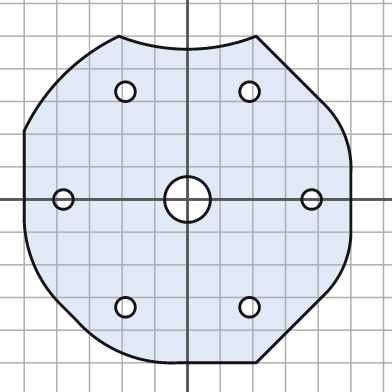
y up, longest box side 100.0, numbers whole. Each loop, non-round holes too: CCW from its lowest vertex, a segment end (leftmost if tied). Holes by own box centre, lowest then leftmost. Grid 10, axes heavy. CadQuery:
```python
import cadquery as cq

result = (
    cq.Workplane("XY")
    .moveTo(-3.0, -50.0)
    .lineTo(21.0, -50.0)
    .lineTo(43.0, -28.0)
    .threePointArc((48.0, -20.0), (50.0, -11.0))
    .lineTo(50.0, 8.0)
    .threePointArc((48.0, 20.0), (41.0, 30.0))
    .lineTo(21.0, 50.0)
    .threePointArc((0.0, 46.0), (-21.0, 50.0))
    .threePointArc((-38.0, 38.0), (-50.0, 21.0))
    .lineTo(-50.0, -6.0)
    .threePointArc((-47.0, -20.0), (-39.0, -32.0))
    .lineTo(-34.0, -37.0)
    .threePointArc((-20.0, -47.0), (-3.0, -50.0))
    .close()
    .moveTo(-19.0, -33.0)
    .circle(3.0)
    .moveTo(19.0, -33.0)
    .circle(3.0)
    .moveTo(-38.0, 0.0)
    .circle(3.0)
    .moveTo(0.0, 0.0)
    .circle(7.0)
    .moveTo(38.0, 0.0)
    .circle(3.0)
    .moveTo(-19.0, 33.0)
    .circle(3.0)
    .moveTo(19.0, 33.0)
    .circle(3.0)
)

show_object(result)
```